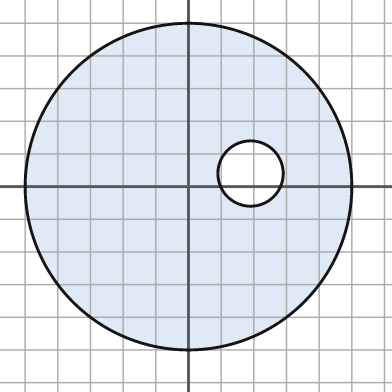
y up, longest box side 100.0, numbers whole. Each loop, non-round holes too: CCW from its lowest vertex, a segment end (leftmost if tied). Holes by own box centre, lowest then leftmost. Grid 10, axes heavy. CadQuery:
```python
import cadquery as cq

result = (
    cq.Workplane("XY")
    .moveTo(0.0, 0.0)
    .circle(50.0)
    .moveTo(19.0, 4.0)
    .circle(10.0)
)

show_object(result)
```